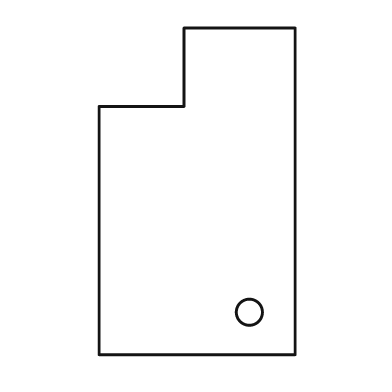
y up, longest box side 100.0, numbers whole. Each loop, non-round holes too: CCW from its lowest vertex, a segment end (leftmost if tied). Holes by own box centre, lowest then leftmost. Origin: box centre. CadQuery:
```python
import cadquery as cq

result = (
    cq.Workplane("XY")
    .moveTo(-30.0, -50.0)
    .lineTo(30.0, -50.0)
    .lineTo(30.0, 50.0)
    .lineTo(-4.0, 50.0)
    .lineTo(-4.0, 26.0)
    .lineTo(-30.0, 26.0)
    .close()
    .moveTo(16.0, -37.0)
    .circle(4.0)
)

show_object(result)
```